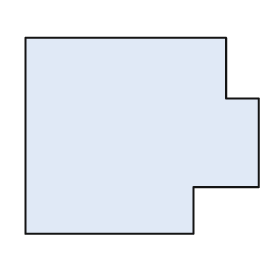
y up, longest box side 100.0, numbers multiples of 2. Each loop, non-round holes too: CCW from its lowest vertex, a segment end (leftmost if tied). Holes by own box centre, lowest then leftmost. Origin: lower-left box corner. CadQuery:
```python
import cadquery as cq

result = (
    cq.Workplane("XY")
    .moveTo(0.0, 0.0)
    .lineTo(72.0, 0.0)
    .lineTo(72.0, 20.0)
    .lineTo(100.0, 20.0)
    .lineTo(100.0, 58.0)
    .lineTo(86.0, 58.0)
    .lineTo(86.0, 84.0)
    .lineTo(0.0, 84.0)
    .close()
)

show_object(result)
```